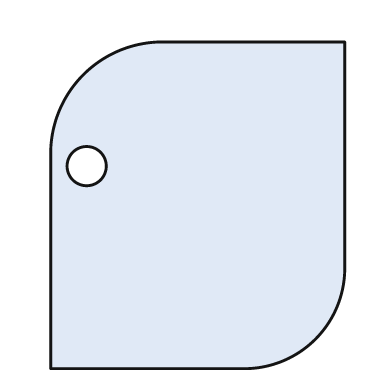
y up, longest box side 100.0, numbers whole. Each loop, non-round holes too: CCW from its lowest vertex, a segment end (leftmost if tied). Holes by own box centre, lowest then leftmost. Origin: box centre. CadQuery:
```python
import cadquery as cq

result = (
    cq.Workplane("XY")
    .moveTo(-45.0, -50.0)
    .lineTo(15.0, -50.0)
    .threePointArc((36.0, -41.0), (45.0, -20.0))
    .lineTo(45.0, 50.0)
    .lineTo(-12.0, 50.0)
    .threePointArc((-35.0, 40.0), (-45.0, 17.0))
    .close()
    .moveTo(-34.0, 12.0)
    .circle(6.0)
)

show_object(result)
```